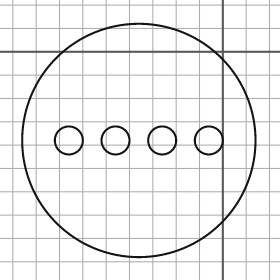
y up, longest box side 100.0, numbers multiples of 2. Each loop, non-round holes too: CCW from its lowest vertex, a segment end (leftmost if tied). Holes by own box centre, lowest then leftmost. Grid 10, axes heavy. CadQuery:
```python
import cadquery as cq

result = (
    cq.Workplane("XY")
    .moveTo(-36.0, -38.0)
    .circle(50.0)
    .moveTo(-66.0, -38.0)
    .circle(6.0)
    .moveTo(-46.0, -38.0)
    .circle(6.0)
    .moveTo(-26.0, -38.0)
    .circle(6.0)
    .moveTo(-6.0, -38.0)
    .circle(6.0)
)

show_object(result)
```